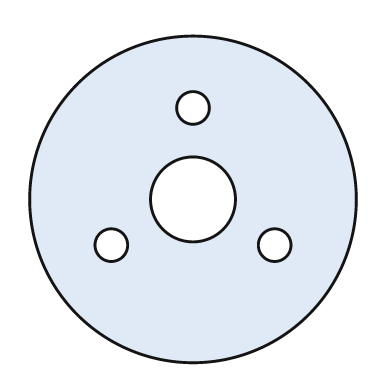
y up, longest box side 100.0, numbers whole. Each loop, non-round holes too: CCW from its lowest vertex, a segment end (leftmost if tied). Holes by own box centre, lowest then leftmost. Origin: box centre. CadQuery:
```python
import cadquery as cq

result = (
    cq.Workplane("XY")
    .moveTo(0.0, 0.0)
    .circle(50.0)
    .moveTo(-25.0, -14.0)
    .circle(5.0)
    .moveTo(25.0, -14.0)
    .circle(5.0)
    .moveTo(0.0, 0.0)
    .circle(13.0)
    .moveTo(0.0, 28.0)
    .circle(5.0)
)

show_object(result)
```